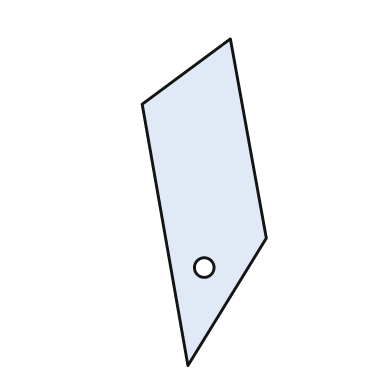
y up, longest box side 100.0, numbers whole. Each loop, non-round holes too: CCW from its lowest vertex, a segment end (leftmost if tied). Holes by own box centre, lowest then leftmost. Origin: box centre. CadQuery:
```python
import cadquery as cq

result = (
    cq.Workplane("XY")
    .moveTo(-5.0, -50.0)
    .lineTo(19.0, -11.0)
    .lineTo(8.0, 50.0)
    .lineTo(-19.0, 30.0)
    .close()
    .moveTo(0.0, -20.0)
    .circle(3.0)
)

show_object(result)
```